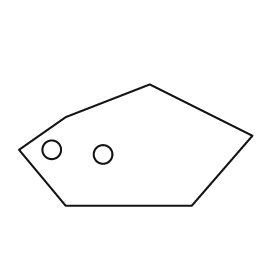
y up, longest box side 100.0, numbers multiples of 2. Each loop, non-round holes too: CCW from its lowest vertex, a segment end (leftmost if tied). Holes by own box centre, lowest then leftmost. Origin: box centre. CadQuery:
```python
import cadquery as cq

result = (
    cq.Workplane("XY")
    .moveTo(-30.0, -26.0)
    .lineTo(24.0, -26.0)
    .lineTo(50.0, 4.0)
    .lineTo(6.0, 26.0)
    .lineTo(-30.0, 12.0)
    .lineTo(-50.0, -2.0)
    .close()
    .moveTo(-14.0, -4.0)
    .circle(4.0)
    .moveTo(-36.0, -2.0)
    .circle(4.0)
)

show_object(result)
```